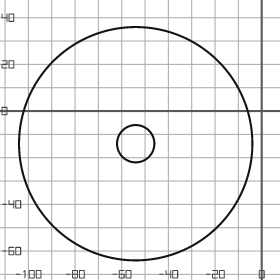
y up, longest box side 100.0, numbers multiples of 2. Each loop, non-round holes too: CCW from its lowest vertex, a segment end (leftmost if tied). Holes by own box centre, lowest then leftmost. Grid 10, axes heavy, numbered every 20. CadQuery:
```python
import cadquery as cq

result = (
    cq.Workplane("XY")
    .moveTo(-54.0, -14.0)
    .circle(50.0)
    .moveTo(-54.0, -14.0)
    .circle(8.0)
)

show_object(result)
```